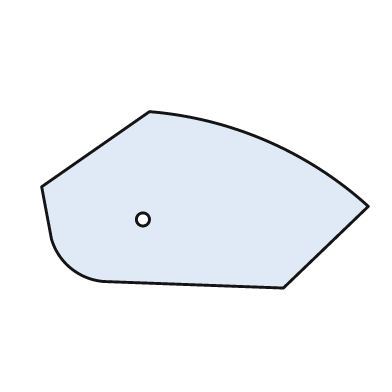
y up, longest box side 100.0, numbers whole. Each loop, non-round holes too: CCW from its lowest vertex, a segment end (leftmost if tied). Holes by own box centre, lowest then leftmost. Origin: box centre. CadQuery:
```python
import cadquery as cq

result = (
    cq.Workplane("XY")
    .moveTo(24.0, -27.0)
    .lineTo(50.0, -2.0)
    .threePointArc((19.0, 18.0), (-17.0, 27.0))
    .lineTo(-50.0, 4.0)
    .lineTo(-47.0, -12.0)
    .threePointArc((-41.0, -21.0), (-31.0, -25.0))
    .close()
    .moveTo(-19.0, -6.0)
    .circle(2.0)
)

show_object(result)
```